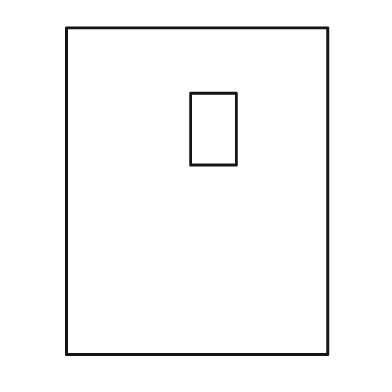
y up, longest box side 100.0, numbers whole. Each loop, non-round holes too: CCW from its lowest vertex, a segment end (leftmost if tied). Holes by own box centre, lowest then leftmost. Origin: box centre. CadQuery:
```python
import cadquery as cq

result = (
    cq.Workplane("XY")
    .moveTo(-40.0, -50.0)
    .lineTo(40.0, -50.0)
    .lineTo(40.0, 50.0)
    .lineTo(-40.0, 50.0)
    .close()
    .moveTo(-2.0, 8.0)
    .lineTo(12.0, 8.0)
    .lineTo(12.0, 30.0)
    .lineTo(-2.0, 30.0)
    .close()
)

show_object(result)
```